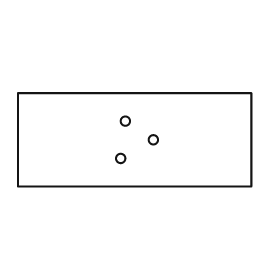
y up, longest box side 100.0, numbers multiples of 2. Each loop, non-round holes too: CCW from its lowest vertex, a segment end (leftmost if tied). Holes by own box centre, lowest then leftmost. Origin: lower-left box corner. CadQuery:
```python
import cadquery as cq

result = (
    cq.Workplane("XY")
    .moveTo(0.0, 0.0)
    .lineTo(100.0, 0.0)
    .lineTo(100.0, 40.0)
    .lineTo(0.0, 40.0)
    .close()
    .moveTo(44.0, 12.0)
    .circle(2.0)
    .moveTo(58.0, 20.0)
    .circle(2.0)
    .moveTo(46.0, 28.0)
    .circle(2.0)
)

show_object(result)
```